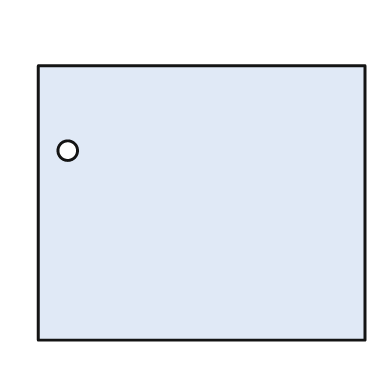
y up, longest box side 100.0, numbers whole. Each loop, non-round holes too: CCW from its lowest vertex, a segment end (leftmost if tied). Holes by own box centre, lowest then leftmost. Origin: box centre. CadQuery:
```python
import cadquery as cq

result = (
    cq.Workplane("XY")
    .moveTo(-50.0, -42.0)
    .lineTo(50.0, -42.0)
    .lineTo(50.0, 42.0)
    .lineTo(-50.0, 42.0)
    .close()
    .moveTo(-41.0, 16.0)
    .circle(3.0)
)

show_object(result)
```